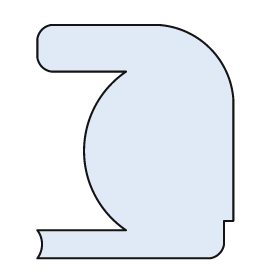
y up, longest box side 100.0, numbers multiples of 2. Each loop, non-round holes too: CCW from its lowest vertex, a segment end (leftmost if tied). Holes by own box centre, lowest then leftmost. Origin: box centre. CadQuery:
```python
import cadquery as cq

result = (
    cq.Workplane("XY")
    .moveTo(-42.0, -50.0)
    .lineTo(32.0, -50.0)
    .threePointArc((36.0, -48.0), (38.0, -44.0))
    .lineTo(38.0, -34.0)
    .lineTo(42.0, -34.0)
    .lineTo(42.0, 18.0)
    .threePointArc((32.0, 40.0), (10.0, 50.0))
    .lineTo(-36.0, 50.0)
    .threePointArc((-40.0, 48.0), (-42.0, 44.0))
    .lineTo(-42.0, 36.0)
    .threePointArc((-40.0, 32.0), (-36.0, 30.0))
    .lineTo(-4.0, 30.0)
    .threePointArc((-22.0, -4.0), (-4.0, -38.0))
    .lineTo(-42.0, -38.0)
    .threePointArc((-40.0, -44.0), (-42.0, -50.0))
    .close()
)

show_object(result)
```